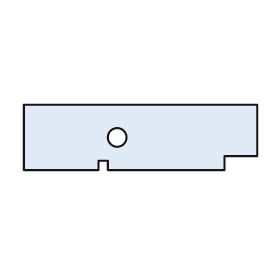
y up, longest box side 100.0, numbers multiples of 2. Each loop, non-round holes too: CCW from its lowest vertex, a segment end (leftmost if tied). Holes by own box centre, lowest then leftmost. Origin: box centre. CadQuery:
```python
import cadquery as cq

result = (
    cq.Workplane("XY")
    .moveTo(-50.0, -14.0)
    .lineTo(-18.0, -14.0)
    .lineTo(-18.0, -10.0)
    .lineTo(-14.0, -10.0)
    .lineTo(-14.0, -14.0)
    .lineTo(36.0, -14.0)
    .lineTo(36.0, -8.0)
    .lineTo(50.0, -8.0)
    .lineTo(50.0, 14.0)
    .lineTo(-50.0, 14.0)
    .close()
    .moveTo(-10.0, 0.0)
    .circle(4.0)
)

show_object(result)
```